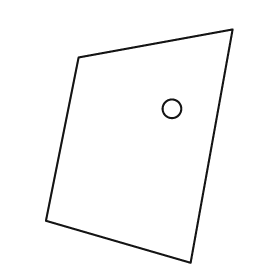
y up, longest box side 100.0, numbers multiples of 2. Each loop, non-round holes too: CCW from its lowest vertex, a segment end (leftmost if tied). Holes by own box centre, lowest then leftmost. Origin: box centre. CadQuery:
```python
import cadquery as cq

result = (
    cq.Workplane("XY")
    .moveTo(22.0, -50.0)
    .lineTo(40.0, 50.0)
    .lineTo(-26.0, 38.0)
    .lineTo(-40.0, -32.0)
    .close()
    .moveTo(14.0, 16.0)
    .circle(4.0)
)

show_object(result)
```